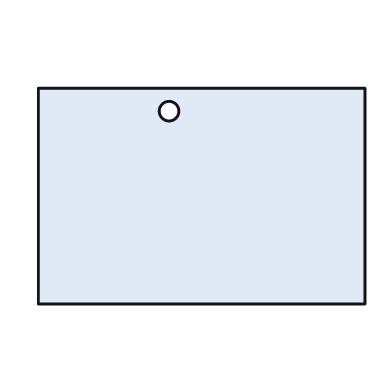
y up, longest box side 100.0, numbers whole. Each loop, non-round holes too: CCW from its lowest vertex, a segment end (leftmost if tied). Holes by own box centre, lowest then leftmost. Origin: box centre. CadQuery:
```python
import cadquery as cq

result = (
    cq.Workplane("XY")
    .moveTo(-50.0, -33.0)
    .lineTo(50.0, -33.0)
    .lineTo(50.0, 33.0)
    .lineTo(-50.0, 33.0)
    .close()
    .moveTo(-10.0, 26.0)
    .circle(3.0)
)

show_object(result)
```